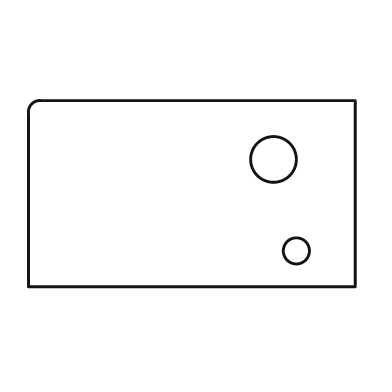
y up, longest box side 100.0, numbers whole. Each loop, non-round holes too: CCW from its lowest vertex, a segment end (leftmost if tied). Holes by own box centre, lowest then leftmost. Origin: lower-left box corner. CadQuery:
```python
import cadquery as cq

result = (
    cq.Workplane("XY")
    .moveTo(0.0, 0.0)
    .lineTo(100.0, 0.0)
    .lineTo(100.0, 57.0)
    .lineTo(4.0, 57.0)
    .threePointArc((1.0, 56.0), (0.0, 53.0))
    .close()
    .moveTo(82.0, 11.0)
    .circle(4.0)
    .moveTo(75.0, 39.0)
    .circle(7.0)
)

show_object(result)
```